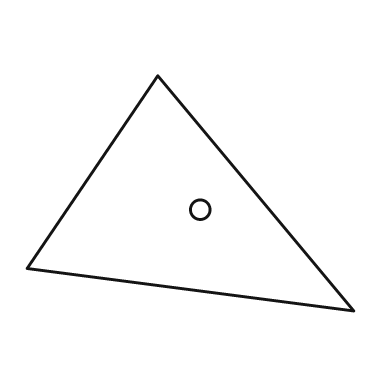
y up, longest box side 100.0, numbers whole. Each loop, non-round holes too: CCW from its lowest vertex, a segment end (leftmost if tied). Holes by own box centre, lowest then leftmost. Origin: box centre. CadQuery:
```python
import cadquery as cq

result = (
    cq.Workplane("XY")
    .moveTo(50.0, -36.0)
    .lineTo(-10.0, 36.0)
    .lineTo(-50.0, -23.0)
    .close()
    .moveTo(3.0, -5.0)
    .circle(3.0)
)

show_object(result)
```